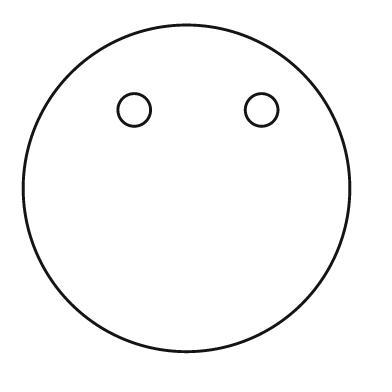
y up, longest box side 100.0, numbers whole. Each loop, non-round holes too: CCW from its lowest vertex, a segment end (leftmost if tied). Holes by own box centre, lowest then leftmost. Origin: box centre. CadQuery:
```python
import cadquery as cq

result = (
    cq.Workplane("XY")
    .moveTo(0.0, 0.0)
    .circle(50.0)
    .moveTo(-16.0, 24.0)
    .circle(5.0)
    .moveTo(23.0, 24.0)
    .circle(5.0)
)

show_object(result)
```